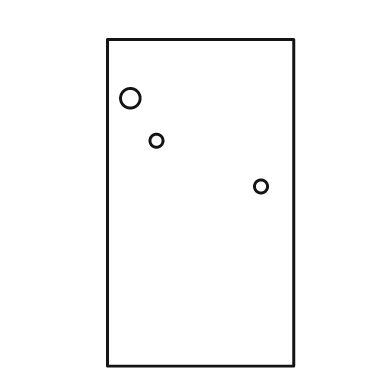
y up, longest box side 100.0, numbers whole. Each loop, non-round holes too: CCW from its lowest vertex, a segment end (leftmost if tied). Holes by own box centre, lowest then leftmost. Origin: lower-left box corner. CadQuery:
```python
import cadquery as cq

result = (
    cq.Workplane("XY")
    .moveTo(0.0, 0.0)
    .lineTo(57.0, 0.0)
    .lineTo(57.0, 100.0)
    .lineTo(0.0, 100.0)
    .close()
    .moveTo(47.0, 55.0)
    .circle(2.0)
    .moveTo(15.0, 69.0)
    .circle(2.0)
    .moveTo(7.0, 82.0)
    .circle(3.0)
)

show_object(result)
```